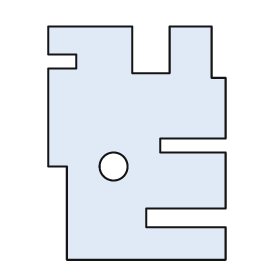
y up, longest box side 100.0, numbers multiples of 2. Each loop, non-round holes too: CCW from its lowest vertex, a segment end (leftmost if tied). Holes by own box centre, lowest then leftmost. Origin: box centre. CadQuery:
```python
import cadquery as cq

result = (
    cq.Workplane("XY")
    .moveTo(-30.0, -50.0)
    .lineTo(38.0, -50.0)
    .lineTo(38.0, -36.0)
    .lineTo(4.0, -36.0)
    .lineTo(4.0, -28.0)
    .lineTo(38.0, -28.0)
    .lineTo(38.0, -4.0)
    .lineTo(10.0, -4.0)
    .lineTo(10.0, 2.0)
    .lineTo(38.0, 2.0)
    .lineTo(38.0, 28.0)
    .lineTo(32.0, 28.0)
    .lineTo(32.0, 50.0)
    .lineTo(14.0, 50.0)
    .lineTo(14.0, 30.0)
    .lineTo(-2.0, 30.0)
    .lineTo(-2.0, 50.0)
    .lineTo(-38.0, 50.0)
    .lineTo(-38.0, 38.0)
    .lineTo(-26.0, 38.0)
    .lineTo(-26.0, 32.0)
    .lineTo(-38.0, 32.0)
    .lineTo(-38.0, -10.0)
    .lineTo(-30.0, -10.0)
    .close()
    .moveTo(-10.0, -10.0)
    .circle(6.0)
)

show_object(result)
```